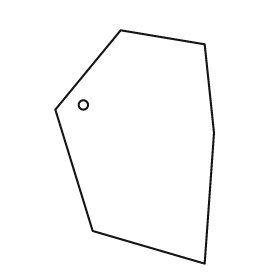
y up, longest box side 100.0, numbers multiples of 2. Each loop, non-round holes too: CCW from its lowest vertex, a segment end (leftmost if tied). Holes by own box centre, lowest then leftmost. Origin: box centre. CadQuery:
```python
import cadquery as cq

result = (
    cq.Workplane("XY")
    .moveTo(30.0, -50.0)
    .lineTo(34.0, 6.0)
    .lineTo(30.0, 44.0)
    .lineTo(-6.0, 50.0)
    .lineTo(-34.0, 16.0)
    .lineTo(-18.0, -36.0)
    .close()
    .moveTo(-22.0, 18.0)
    .circle(2.0)
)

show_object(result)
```